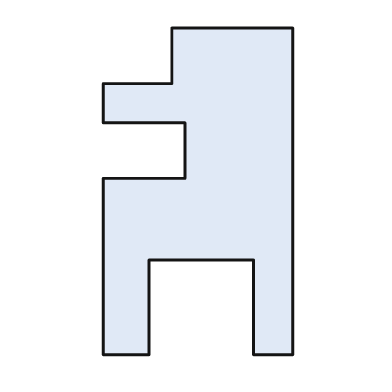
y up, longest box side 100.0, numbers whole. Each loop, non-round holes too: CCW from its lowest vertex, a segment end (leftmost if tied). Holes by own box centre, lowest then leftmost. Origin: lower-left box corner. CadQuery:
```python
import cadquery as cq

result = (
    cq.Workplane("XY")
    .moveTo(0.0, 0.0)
    .lineTo(14.0, 0.0)
    .lineTo(14.0, 29.0)
    .lineTo(46.0, 29.0)
    .lineTo(46.0, 0.0)
    .lineTo(58.0, 0.0)
    .lineTo(58.0, 100.0)
    .lineTo(21.0, 100.0)
    .lineTo(21.0, 83.0)
    .lineTo(0.0, 83.0)
    .lineTo(0.0, 71.0)
    .lineTo(25.0, 71.0)
    .lineTo(25.0, 54.0)
    .lineTo(0.0, 54.0)
    .close()
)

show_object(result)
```